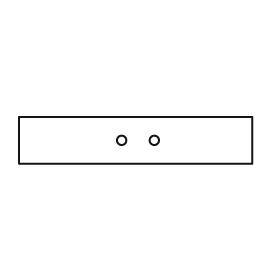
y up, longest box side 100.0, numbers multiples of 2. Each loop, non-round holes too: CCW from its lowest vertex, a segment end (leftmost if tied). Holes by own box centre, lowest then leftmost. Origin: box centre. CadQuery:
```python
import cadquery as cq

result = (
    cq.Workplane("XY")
    .moveTo(-50.0, -10.0)
    .lineTo(50.0, -10.0)
    .lineTo(50.0, 10.0)
    .lineTo(-50.0, 10.0)
    .close()
    .moveTo(-6.0, 0.0)
    .circle(2.0)
    .moveTo(8.0, 0.0)
    .circle(2.0)
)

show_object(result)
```